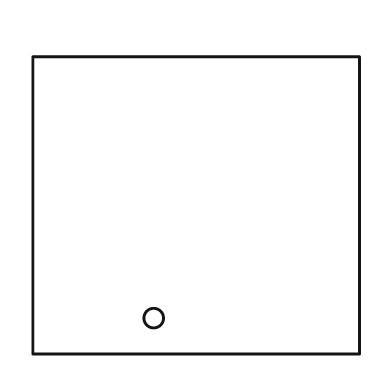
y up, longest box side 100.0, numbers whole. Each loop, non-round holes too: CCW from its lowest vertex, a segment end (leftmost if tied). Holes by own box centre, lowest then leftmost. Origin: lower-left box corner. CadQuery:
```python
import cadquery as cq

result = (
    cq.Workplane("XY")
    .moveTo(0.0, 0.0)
    .lineTo(100.0, 0.0)
    .lineTo(100.0, 91.0)
    .lineTo(0.0, 91.0)
    .close()
    .moveTo(37.0, 11.0)
    .circle(3.0)
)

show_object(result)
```